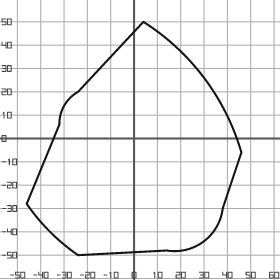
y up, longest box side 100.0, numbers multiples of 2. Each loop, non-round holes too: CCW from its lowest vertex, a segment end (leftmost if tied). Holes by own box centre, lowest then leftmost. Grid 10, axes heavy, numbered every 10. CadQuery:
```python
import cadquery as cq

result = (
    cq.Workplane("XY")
    .moveTo(-24.0, -50.0)
    .lineTo(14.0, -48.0)
    .threePointArc((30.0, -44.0), (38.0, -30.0))
    .lineTo(46.0, -6.0)
    .threePointArc((30.0, 26.0), (4.0, 50.0))
    .lineTo(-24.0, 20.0)
    .threePointArc((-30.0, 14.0), (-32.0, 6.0))
    .lineTo(-46.0, -28.0)
    .threePointArc((-36.0, -40.0), (-24.0, -50.0))
    .close()
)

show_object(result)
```